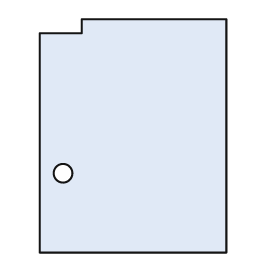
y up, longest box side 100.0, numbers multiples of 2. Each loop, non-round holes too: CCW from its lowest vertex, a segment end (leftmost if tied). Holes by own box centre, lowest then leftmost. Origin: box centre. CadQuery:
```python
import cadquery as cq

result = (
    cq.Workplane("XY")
    .moveTo(-40.0, -50.0)
    .lineTo(40.0, -50.0)
    .lineTo(40.0, 50.0)
    .lineTo(-22.0, 50.0)
    .lineTo(-22.0, 44.0)
    .lineTo(-40.0, 44.0)
    .close()
    .moveTo(-30.0, -16.0)
    .circle(4.0)
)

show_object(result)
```